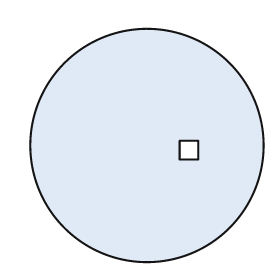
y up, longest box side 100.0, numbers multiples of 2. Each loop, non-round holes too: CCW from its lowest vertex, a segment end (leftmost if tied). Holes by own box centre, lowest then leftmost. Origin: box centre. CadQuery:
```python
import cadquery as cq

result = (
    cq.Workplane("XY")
    .moveTo(0.0, 0.0)
    .circle(50.0)
    .moveTo(14.0, -6.0)
    .lineTo(22.0, -6.0)
    .lineTo(22.0, 2.0)
    .lineTo(14.0, 2.0)
    .close()
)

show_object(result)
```